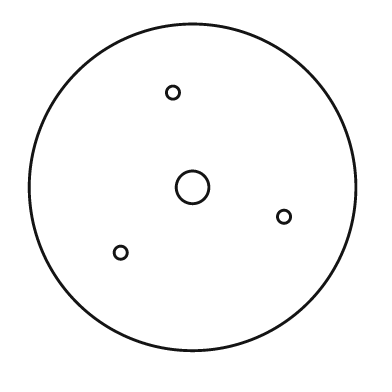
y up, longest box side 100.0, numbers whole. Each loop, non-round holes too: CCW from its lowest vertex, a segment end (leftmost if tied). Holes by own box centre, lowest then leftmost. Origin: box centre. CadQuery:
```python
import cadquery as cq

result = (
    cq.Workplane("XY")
    .moveTo(0.0, 0.0)
    .circle(50.0)
    .moveTo(-22.0, -20.0)
    .circle(2.0)
    .moveTo(28.0, -9.0)
    .circle(2.0)
    .moveTo(0.0, 0.0)
    .circle(5.0)
    .moveTo(-6.0, 29.0)
    .circle(2.0)
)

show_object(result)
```